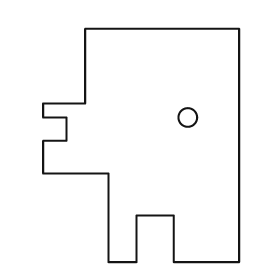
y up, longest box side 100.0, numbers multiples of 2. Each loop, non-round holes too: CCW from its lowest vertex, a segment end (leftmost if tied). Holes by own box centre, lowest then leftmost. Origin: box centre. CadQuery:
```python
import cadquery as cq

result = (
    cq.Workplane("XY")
    .moveTo(-14.0, -50.0)
    .lineTo(-2.0, -50.0)
    .lineTo(-2.0, -30.0)
    .lineTo(14.0, -30.0)
    .lineTo(14.0, -50.0)
    .lineTo(42.0, -50.0)
    .lineTo(42.0, 50.0)
    .lineTo(-24.0, 50.0)
    .lineTo(-24.0, 18.0)
    .lineTo(-42.0, 18.0)
    .lineTo(-42.0, 12.0)
    .lineTo(-32.0, 12.0)
    .lineTo(-32.0, 2.0)
    .lineTo(-42.0, 2.0)
    .lineTo(-42.0, -12.0)
    .lineTo(-14.0, -12.0)
    .close()
    .moveTo(20.0, 12.0)
    .circle(4.0)
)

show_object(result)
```